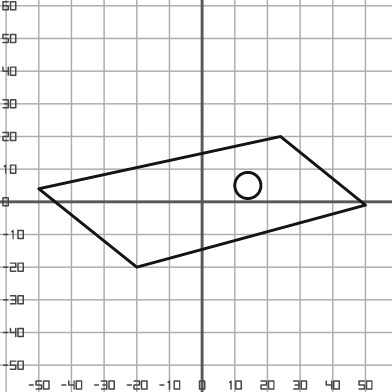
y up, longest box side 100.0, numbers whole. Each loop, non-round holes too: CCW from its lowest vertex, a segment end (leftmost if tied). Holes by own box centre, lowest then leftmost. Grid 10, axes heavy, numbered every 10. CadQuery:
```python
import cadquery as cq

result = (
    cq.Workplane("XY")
    .moveTo(-20.0, -20.0)
    .lineTo(50.0, -1.0)
    .lineTo(24.0, 20.0)
    .lineTo(-50.0, 4.0)
    .close()
    .moveTo(14.0, 5.0)
    .circle(4.0)
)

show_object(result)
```